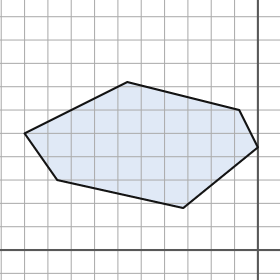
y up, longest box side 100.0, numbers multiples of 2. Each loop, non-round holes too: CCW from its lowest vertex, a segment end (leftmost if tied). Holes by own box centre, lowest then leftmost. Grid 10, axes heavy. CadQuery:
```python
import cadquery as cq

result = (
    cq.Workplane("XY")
    .moveTo(-32.0, 18.0)
    .lineTo(0.0, 44.0)
    .lineTo(-8.0, 60.0)
    .lineTo(-56.0, 72.0)
    .lineTo(-100.0, 50.0)
    .lineTo(-86.0, 30.0)
    .close()
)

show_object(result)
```